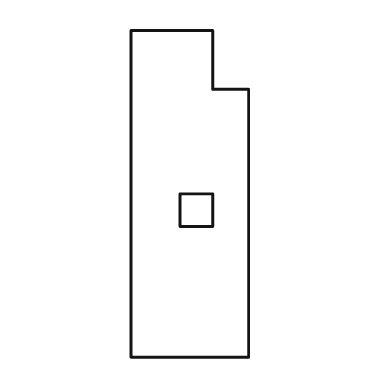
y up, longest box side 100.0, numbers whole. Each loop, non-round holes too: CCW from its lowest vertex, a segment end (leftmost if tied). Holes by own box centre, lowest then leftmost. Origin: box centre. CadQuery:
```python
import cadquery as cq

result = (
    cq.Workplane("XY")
    .moveTo(-18.0, -50.0)
    .lineTo(18.0, -50.0)
    .lineTo(18.0, 32.0)
    .lineTo(7.0, 32.0)
    .lineTo(7.0, 50.0)
    .lineTo(-18.0, 50.0)
    .close()
    .moveTo(-3.0, -10.0)
    .lineTo(7.0, -10.0)
    .lineTo(7.0, 0.0)
    .lineTo(-3.0, 0.0)
    .close()
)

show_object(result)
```